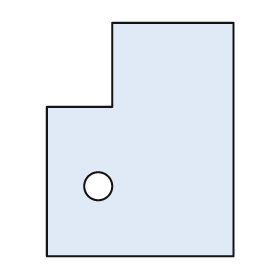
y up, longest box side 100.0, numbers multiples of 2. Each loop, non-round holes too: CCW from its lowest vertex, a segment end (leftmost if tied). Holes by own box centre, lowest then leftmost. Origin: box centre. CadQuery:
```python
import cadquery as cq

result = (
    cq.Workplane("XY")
    .moveTo(-40.0, -50.0)
    .lineTo(40.0, -50.0)
    .lineTo(40.0, 50.0)
    .lineTo(-12.0, 50.0)
    .lineTo(-12.0, 14.0)
    .lineTo(-40.0, 14.0)
    .close()
    .moveTo(-18.0, -20.0)
    .circle(6.0)
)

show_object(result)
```